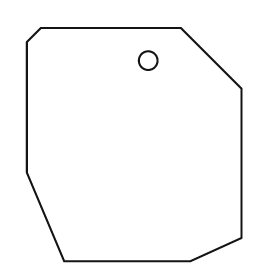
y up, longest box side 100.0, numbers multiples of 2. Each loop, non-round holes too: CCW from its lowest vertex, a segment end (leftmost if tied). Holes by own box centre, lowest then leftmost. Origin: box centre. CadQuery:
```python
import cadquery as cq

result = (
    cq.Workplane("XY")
    .moveTo(-30.0, -50.0)
    .lineTo(24.0, -50.0)
    .lineTo(46.0, -40.0)
    .lineTo(46.0, 24.0)
    .lineTo(20.0, 50.0)
    .lineTo(-40.0, 50.0)
    .lineTo(-46.0, 44.0)
    .lineTo(-46.0, -12.0)
    .close()
    .moveTo(6.0, 36.0)
    .circle(4.0)
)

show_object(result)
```